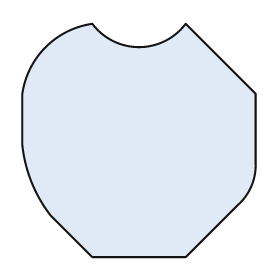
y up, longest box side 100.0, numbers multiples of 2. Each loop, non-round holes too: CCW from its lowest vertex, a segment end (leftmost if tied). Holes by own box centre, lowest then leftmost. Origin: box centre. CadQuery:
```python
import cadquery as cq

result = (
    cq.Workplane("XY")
    .moveTo(-20.0, -50.0)
    .lineTo(20.0, -50.0)
    .lineTo(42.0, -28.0)
    .threePointArc((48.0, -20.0), (50.0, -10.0))
    .lineTo(50.0, 20.0)
    .lineTo(20.0, 50.0)
    .threePointArc((0.0, 40.0), (-20.0, 50.0))
    .threePointArc((-40.0, 40.0), (-50.0, 20.0))
    .lineTo(-50.0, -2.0)
    .threePointArc((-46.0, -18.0), (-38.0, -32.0))
    .close()
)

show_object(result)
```